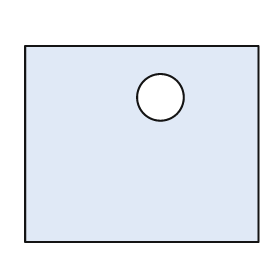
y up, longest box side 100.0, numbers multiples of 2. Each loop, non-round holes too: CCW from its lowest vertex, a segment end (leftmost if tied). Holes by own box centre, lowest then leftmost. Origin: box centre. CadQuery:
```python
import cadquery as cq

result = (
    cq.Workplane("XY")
    .moveTo(-50.0, -42.0)
    .lineTo(50.0, -42.0)
    .lineTo(50.0, 42.0)
    .lineTo(-50.0, 42.0)
    .close()
    .moveTo(8.0, 20.0)
    .circle(10.0)
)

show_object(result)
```